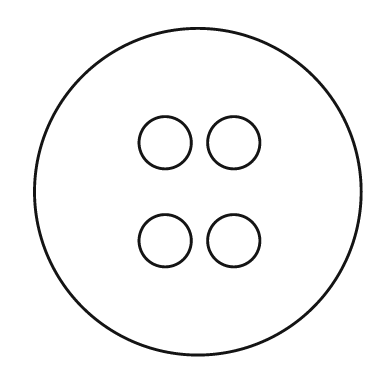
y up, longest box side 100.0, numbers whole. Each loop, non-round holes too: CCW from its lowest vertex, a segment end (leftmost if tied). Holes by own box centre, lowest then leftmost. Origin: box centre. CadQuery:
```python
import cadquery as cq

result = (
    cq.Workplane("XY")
    .moveTo(0.0, 0.0)
    .circle(50.0)
    .moveTo(-10.0, -15.0)
    .circle(8.0)
    .moveTo(11.0, -15.0)
    .circle(8.0)
    .moveTo(-10.0, 15.0)
    .circle(8.0)
    .moveTo(11.0, 15.0)
    .circle(8.0)
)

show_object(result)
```